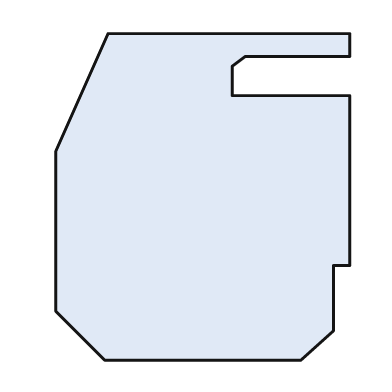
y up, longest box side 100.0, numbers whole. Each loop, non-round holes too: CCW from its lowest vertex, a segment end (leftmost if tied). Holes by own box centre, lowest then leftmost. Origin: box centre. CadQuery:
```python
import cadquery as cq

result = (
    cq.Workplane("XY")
    .moveTo(-30.0, -50.0)
    .lineTo(30.0, -50.0)
    .lineTo(40.0, -41.0)
    .lineTo(40.0, -21.0)
    .lineTo(45.0, -21.0)
    .lineTo(45.0, 31.0)
    .lineTo(9.0, 31.0)
    .lineTo(9.0, 40.0)
    .lineTo(13.0, 43.0)
    .lineTo(45.0, 43.0)
    .lineTo(45.0, 50.0)
    .lineTo(-29.0, 50.0)
    .lineTo(-45.0, 14.0)
    .lineTo(-45.0, -35.0)
    .close()
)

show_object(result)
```